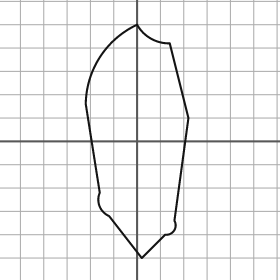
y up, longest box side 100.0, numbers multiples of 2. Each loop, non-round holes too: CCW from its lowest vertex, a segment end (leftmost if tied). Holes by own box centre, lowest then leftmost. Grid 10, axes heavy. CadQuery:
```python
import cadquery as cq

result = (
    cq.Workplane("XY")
    .moveTo(2.0, -50.0)
    .lineTo(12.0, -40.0)
    .threePointArc((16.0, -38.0), (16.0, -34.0))
    .lineTo(22.0, 10.0)
    .lineTo(14.0, 42.0)
    .threePointArc((6.0, 44.0), (0.0, 50.0))
    .threePointArc((-16.0, 36.0), (-22.0, 16.0))
    .lineTo(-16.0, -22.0)
    .threePointArc((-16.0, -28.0), (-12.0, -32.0))
    .close()
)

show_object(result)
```